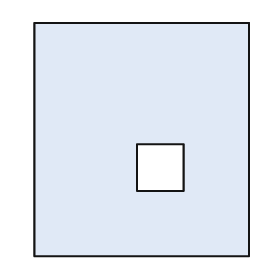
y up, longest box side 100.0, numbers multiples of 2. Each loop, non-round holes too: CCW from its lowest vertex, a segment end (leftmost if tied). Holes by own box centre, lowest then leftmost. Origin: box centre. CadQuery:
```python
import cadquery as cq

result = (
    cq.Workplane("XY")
    .moveTo(-46.0, -50.0)
    .lineTo(46.0, -50.0)
    .lineTo(46.0, 50.0)
    .lineTo(-46.0, 50.0)
    .close()
    .moveTo(-2.0, -22.0)
    .lineTo(18.0, -22.0)
    .lineTo(18.0, -2.0)
    .lineTo(-2.0, -2.0)
    .close()
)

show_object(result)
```